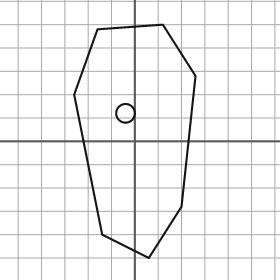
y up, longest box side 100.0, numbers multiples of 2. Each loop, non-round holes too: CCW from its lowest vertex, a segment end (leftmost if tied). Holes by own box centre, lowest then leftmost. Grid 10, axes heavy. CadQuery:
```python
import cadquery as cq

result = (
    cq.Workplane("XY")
    .moveTo(6.0, -50.0)
    .lineTo(20.0, -28.0)
    .lineTo(26.0, 28.0)
    .lineTo(12.0, 50.0)
    .lineTo(-16.0, 48.0)
    .lineTo(-26.0, 20.0)
    .lineTo(-14.0, -40.0)
    .close()
    .moveTo(-4.0, 12.0)
    .circle(4.0)
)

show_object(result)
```